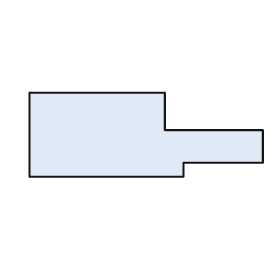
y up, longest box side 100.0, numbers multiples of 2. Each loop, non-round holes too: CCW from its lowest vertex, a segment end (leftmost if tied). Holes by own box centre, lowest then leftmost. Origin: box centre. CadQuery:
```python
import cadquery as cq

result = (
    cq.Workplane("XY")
    .moveTo(-50.0, -18.0)
    .lineTo(16.0, -18.0)
    .lineTo(16.0, -12.0)
    .lineTo(50.0, -12.0)
    .lineTo(50.0, 2.0)
    .lineTo(8.0, 2.0)
    .lineTo(8.0, 18.0)
    .lineTo(-50.0, 18.0)
    .close()
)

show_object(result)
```